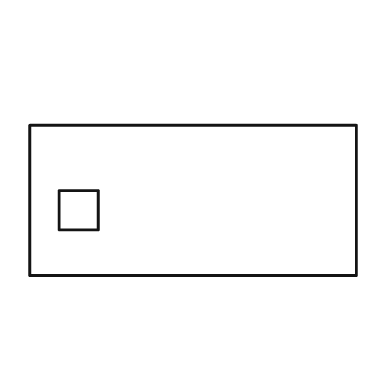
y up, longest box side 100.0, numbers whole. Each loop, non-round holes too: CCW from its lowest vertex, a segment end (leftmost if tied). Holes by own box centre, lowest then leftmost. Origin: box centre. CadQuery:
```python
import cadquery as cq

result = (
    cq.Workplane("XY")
    .moveTo(-50.0, -23.0)
    .lineTo(50.0, -23.0)
    .lineTo(50.0, 23.0)
    .lineTo(-50.0, 23.0)
    .close()
    .moveTo(-41.0, -9.0)
    .lineTo(-29.0, -9.0)
    .lineTo(-29.0, 3.0)
    .lineTo(-41.0, 3.0)
    .close()
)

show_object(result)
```